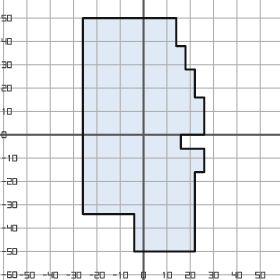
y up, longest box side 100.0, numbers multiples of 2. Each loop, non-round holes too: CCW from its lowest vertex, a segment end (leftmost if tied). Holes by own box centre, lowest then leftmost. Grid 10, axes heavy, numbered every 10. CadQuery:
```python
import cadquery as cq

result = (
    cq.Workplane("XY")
    .moveTo(-4.0, -50.0)
    .lineTo(22.0, -50.0)
    .lineTo(22.0, -16.0)
    .lineTo(26.0, -16.0)
    .lineTo(26.0, -6.0)
    .lineTo(16.0, -6.0)
    .lineTo(16.0, 0.0)
    .lineTo(26.0, 0.0)
    .lineTo(26.0, 16.0)
    .lineTo(22.0, 16.0)
    .lineTo(22.0, 28.0)
    .lineTo(18.0, 28.0)
    .lineTo(18.0, 38.0)
    .lineTo(14.0, 38.0)
    .lineTo(14.0, 50.0)
    .lineTo(-26.0, 50.0)
    .lineTo(-26.0, -34.0)
    .lineTo(-4.0, -34.0)
    .close()
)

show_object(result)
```